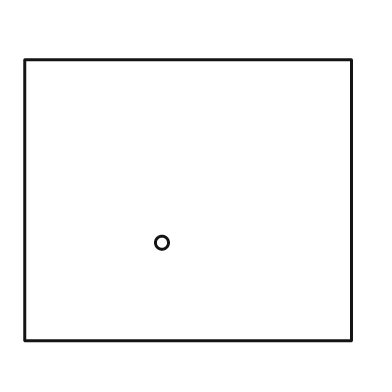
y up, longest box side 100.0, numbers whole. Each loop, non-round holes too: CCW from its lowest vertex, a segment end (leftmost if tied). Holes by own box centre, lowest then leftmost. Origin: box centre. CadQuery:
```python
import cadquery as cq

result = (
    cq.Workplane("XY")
    .moveTo(-50.0, -43.0)
    .lineTo(50.0, -43.0)
    .lineTo(50.0, 43.0)
    .lineTo(-50.0, 43.0)
    .close()
    .moveTo(-8.0, -13.0)
    .circle(2.0)
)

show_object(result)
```